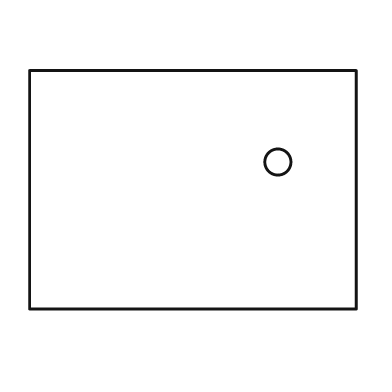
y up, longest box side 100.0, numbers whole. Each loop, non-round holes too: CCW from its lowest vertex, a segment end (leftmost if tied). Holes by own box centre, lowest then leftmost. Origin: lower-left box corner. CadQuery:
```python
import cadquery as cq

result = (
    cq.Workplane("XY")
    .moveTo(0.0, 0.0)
    .lineTo(100.0, 0.0)
    .lineTo(100.0, 73.0)
    .lineTo(0.0, 73.0)
    .close()
    .moveTo(76.0, 45.0)
    .circle(4.0)
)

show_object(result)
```